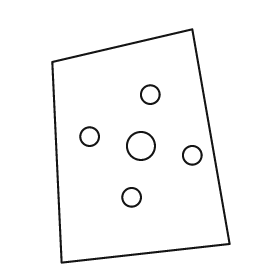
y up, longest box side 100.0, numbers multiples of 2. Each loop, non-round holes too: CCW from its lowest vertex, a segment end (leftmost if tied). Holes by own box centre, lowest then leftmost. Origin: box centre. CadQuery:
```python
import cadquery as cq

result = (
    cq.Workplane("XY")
    .moveTo(-34.0, -50.0)
    .lineTo(38.0, -42.0)
    .lineTo(22.0, 50.0)
    .lineTo(-38.0, 36.0)
    .close()
    .moveTo(-4.0, -22.0)
    .circle(4.0)
    .moveTo(22.0, -4.0)
    .circle(4.0)
    .moveTo(0.0, 0.0)
    .circle(6.0)
    .moveTo(-22.0, 4.0)
    .circle(4.0)
    .moveTo(4.0, 22.0)
    .circle(4.0)
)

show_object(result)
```